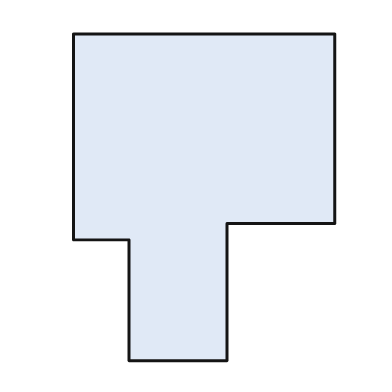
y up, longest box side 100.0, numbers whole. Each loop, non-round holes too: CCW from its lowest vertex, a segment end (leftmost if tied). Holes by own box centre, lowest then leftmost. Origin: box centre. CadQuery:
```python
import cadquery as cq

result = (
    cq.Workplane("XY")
    .moveTo(-23.0, -50.0)
    .lineTo(7.0, -50.0)
    .lineTo(7.0, -8.0)
    .lineTo(40.0, -8.0)
    .lineTo(40.0, 50.0)
    .lineTo(-40.0, 50.0)
    .lineTo(-40.0, -13.0)
    .lineTo(-23.0, -13.0)
    .close()
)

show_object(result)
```